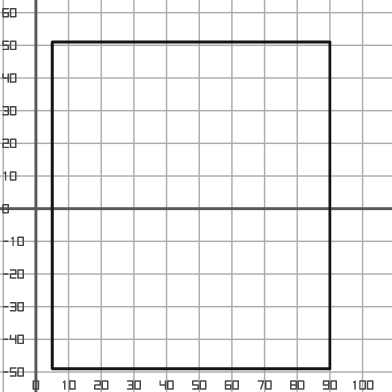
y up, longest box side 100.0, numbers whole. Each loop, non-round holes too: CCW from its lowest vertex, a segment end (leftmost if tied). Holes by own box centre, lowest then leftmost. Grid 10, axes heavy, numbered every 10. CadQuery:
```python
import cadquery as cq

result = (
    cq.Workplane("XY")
    .moveTo(5.0, -49.0)
    .lineTo(90.0, -49.0)
    .lineTo(90.0, 51.0)
    .lineTo(5.0, 51.0)
    .close()
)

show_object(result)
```